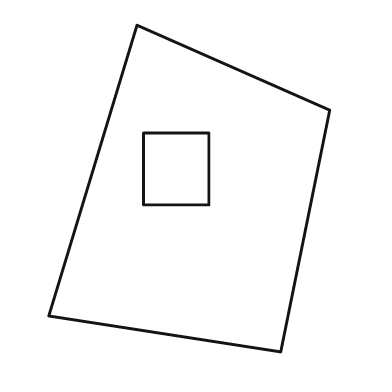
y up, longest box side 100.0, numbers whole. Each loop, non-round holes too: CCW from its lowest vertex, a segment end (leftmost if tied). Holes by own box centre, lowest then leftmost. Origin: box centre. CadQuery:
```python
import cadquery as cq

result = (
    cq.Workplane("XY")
    .moveTo(28.0, -50.0)
    .lineTo(43.0, 24.0)
    .lineTo(-16.0, 50.0)
    .lineTo(-43.0, -39.0)
    .close()
    .moveTo(-14.0, -5.0)
    .lineTo(6.0, -5.0)
    .lineTo(6.0, 17.0)
    .lineTo(-14.0, 17.0)
    .close()
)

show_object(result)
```